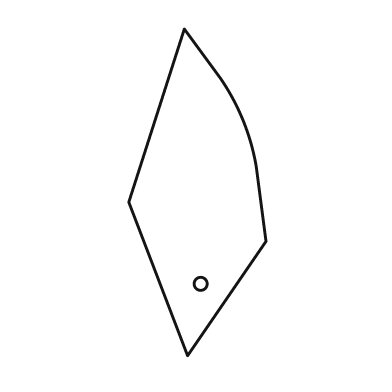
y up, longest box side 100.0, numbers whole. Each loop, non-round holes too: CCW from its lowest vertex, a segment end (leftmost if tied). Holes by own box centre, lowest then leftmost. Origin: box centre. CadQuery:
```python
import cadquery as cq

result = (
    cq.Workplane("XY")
    .moveTo(-3.0, -50.0)
    .lineTo(21.0, -15.0)
    .lineTo(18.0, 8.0)
    .threePointArc((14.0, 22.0), (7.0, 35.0))
    .lineTo(-4.0, 50.0)
    .lineTo(-21.0, -3.0)
    .close()
    .moveTo(1.0, -28.0)
    .circle(2.0)
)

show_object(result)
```